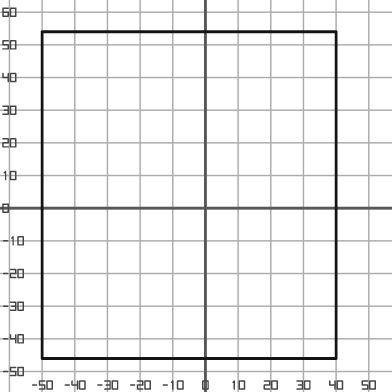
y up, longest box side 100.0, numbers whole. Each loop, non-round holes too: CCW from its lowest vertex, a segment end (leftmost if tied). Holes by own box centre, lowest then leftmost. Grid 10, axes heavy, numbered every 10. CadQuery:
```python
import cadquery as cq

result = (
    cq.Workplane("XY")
    .moveTo(-50.0, -46.0)
    .lineTo(40.0, -46.0)
    .lineTo(40.0, 54.0)
    .lineTo(-50.0, 54.0)
    .close()
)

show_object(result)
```